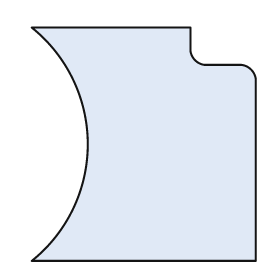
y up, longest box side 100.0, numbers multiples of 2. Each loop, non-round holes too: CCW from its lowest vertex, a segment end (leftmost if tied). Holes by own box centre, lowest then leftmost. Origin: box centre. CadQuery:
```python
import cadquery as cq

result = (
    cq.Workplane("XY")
    .moveTo(-48.0, -50.0)
    .lineTo(48.0, -50.0)
    .lineTo(48.0, 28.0)
    .threePointArc((46.0, 32.0), (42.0, 34.0))
    .lineTo(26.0, 34.0)
    .threePointArc((22.0, 36.0), (20.0, 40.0))
    .lineTo(20.0, 50.0)
    .lineTo(-48.0, 50.0)
    .threePointArc((-24.0, 0.0), (-48.0, -50.0))
    .close()
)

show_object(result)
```